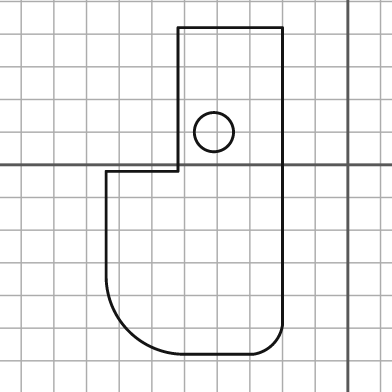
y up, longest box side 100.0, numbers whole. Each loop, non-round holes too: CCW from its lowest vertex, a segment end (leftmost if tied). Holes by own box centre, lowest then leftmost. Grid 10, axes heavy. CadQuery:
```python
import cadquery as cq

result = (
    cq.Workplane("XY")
    .moveTo(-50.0, -58.0)
    .lineTo(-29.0, -58.0)
    .threePointArc((-23.0, -55.0), (-20.0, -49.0))
    .lineTo(-20.0, 42.0)
    .lineTo(-52.0, 42.0)
    .lineTo(-52.0, -2.0)
    .lineTo(-74.0, -2.0)
    .lineTo(-74.0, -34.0)
    .threePointArc((-67.0, -51.0), (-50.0, -58.0))
    .close()
    .moveTo(-41.0, 10.0)
    .circle(6.0)
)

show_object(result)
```